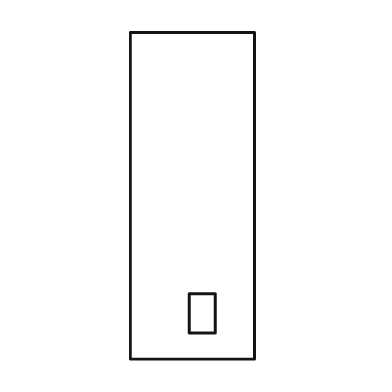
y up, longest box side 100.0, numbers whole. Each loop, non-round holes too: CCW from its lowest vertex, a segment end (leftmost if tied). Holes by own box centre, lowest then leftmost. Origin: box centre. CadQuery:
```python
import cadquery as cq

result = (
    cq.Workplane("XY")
    .moveTo(-19.0, -50.0)
    .lineTo(19.0, -50.0)
    .lineTo(19.0, 50.0)
    .lineTo(-19.0, 50.0)
    .close()
    .moveTo(-1.0, -42.0)
    .lineTo(7.0, -42.0)
    .lineTo(7.0, -30.0)
    .lineTo(-1.0, -30.0)
    .close()
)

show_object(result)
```